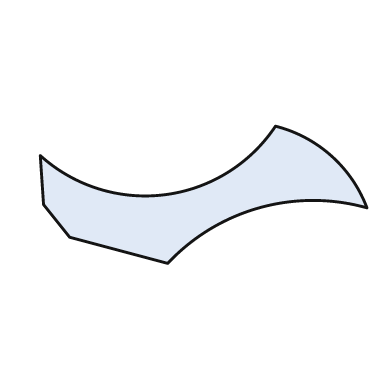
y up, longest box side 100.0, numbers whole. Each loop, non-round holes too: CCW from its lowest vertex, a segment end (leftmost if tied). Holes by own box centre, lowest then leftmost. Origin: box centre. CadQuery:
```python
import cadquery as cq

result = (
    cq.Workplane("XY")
    .moveTo(-11.0, -21.0)
    .threePointArc((17.0, -4.0), (50.0, -4.0))
    .threePointArc((39.0, 12.0), (22.0, 21.0))
    .threePointArc((-12.0, 0.0), (-50.0, 12.0))
    .lineTo(-49.0, -3.0)
    .lineTo(-41.0, -13.0)
    .close()
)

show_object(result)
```